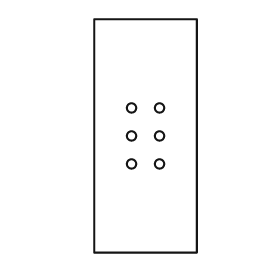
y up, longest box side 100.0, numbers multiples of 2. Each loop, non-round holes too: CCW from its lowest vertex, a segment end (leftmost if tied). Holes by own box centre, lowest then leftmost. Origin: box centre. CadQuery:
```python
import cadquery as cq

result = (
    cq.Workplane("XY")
    .moveTo(-22.0, -50.0)
    .lineTo(22.0, -50.0)
    .lineTo(22.0, 50.0)
    .lineTo(-22.0, 50.0)
    .close()
    .moveTo(-6.0, -12.0)
    .circle(2.0)
    .moveTo(6.0, -12.0)
    .circle(2.0)
    .moveTo(-6.0, 0.0)
    .circle(2.0)
    .moveTo(6.0, 0.0)
    .circle(2.0)
    .moveTo(-6.0, 12.0)
    .circle(2.0)
    .moveTo(6.0, 12.0)
    .circle(2.0)
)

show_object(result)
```